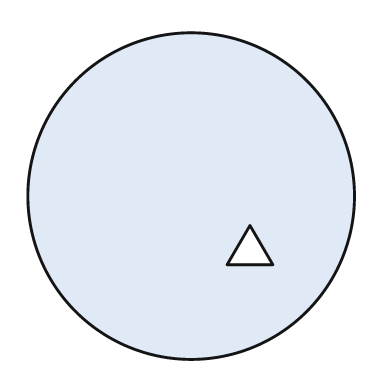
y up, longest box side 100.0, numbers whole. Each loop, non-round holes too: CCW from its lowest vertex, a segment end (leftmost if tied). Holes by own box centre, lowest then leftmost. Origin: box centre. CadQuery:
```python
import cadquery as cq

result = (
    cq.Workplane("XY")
    .moveTo(0.0, 0.0)
    .circle(50.0)
    .moveTo(11.0, -21.0)
    .lineTo(25.0, -21.0)
    .lineTo(18.0, -9.0)
    .close()
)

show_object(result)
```